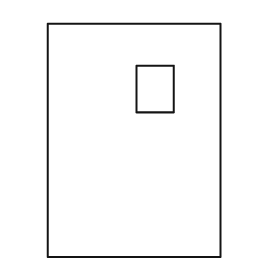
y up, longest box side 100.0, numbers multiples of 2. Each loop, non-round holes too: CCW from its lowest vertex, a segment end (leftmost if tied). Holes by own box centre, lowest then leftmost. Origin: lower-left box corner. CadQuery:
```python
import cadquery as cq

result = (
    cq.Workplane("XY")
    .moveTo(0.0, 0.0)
    .lineTo(74.0, 0.0)
    .lineTo(74.0, 100.0)
    .lineTo(0.0, 100.0)
    .close()
    .moveTo(38.0, 62.0)
    .lineTo(54.0, 62.0)
    .lineTo(54.0, 82.0)
    .lineTo(38.0, 82.0)
    .close()
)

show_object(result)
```